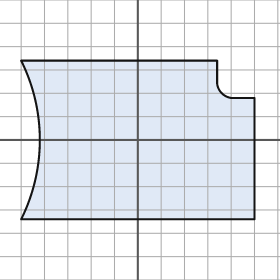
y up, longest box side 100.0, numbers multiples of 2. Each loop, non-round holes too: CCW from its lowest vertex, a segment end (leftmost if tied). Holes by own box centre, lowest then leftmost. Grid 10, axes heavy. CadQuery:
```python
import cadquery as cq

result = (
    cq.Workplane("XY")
    .moveTo(-50.0, -34.0)
    .lineTo(50.0, -34.0)
    .lineTo(50.0, 18.0)
    .lineTo(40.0, 18.0)
    .threePointArc((36.0, 20.0), (34.0, 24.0))
    .lineTo(34.0, 34.0)
    .lineTo(-50.0, 34.0)
    .threePointArc((-42.0, 0.0), (-50.0, -34.0))
    .close()
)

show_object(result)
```